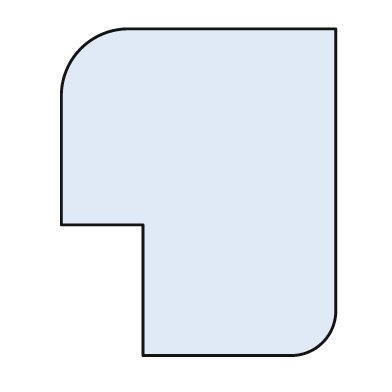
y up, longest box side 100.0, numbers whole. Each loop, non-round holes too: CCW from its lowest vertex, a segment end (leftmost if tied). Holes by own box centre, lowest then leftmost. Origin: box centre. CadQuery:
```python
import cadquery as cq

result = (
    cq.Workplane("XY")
    .moveTo(-17.0, -50.0)
    .lineTo(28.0, -50.0)
    .threePointArc((38.0, -46.0), (42.0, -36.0))
    .lineTo(42.0, 50.0)
    .lineTo(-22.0, 50.0)
    .threePointArc((-36.0, 44.0), (-42.0, 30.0))
    .lineTo(-42.0, -10.0)
    .lineTo(-17.0, -10.0)
    .close()
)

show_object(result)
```